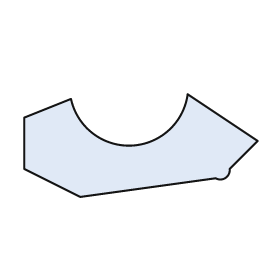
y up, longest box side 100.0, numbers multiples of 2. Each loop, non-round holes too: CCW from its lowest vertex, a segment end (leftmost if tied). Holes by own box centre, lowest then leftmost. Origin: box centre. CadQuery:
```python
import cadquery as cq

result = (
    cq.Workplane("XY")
    .moveTo(-26.0, -22.0)
    .lineTo(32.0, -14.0)
    .threePointArc((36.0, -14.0), (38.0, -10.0))
    .lineTo(50.0, 2.0)
    .lineTo(20.0, 22.0)
    .threePointArc((-4.0, 0.0), (-30.0, 20.0))
    .lineTo(-50.0, 12.0)
    .lineTo(-50.0, -10.0)
    .close()
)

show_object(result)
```